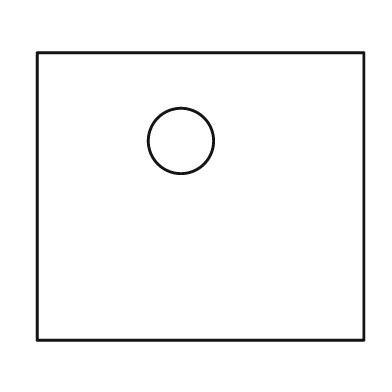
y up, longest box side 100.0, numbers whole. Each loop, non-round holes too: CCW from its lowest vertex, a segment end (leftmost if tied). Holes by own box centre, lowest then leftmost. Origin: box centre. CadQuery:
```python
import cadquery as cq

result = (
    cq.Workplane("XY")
    .moveTo(-50.0, -44.0)
    .lineTo(50.0, -44.0)
    .lineTo(50.0, 44.0)
    .lineTo(-50.0, 44.0)
    .close()
    .moveTo(-6.0, 17.0)
    .circle(10.0)
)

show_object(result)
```